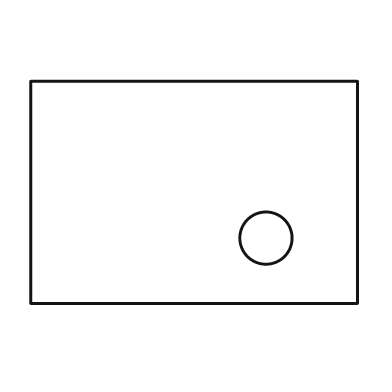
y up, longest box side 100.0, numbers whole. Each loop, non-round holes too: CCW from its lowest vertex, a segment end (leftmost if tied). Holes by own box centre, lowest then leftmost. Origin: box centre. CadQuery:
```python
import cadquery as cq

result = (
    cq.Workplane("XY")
    .moveTo(-50.0, -34.0)
    .lineTo(50.0, -34.0)
    .lineTo(50.0, 34.0)
    .lineTo(-50.0, 34.0)
    .close()
    .moveTo(22.0, -14.0)
    .circle(8.0)
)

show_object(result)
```